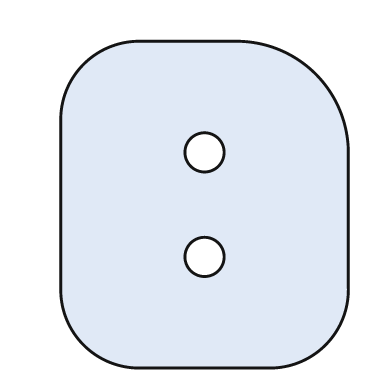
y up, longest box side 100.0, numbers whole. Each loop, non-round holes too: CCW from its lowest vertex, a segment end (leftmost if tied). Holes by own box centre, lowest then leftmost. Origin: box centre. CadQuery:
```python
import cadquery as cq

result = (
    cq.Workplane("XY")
    .moveTo(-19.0, -50.0)
    .lineTo(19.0, -50.0)
    .threePointArc((37.0, -43.0), (44.0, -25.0))
    .lineTo(44.0, 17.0)
    .threePointArc((34.0, 40.0), (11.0, 50.0))
    .lineTo(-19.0, 50.0)
    .threePointArc((-37.0, 43.0), (-44.0, 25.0))
    .lineTo(-44.0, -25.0)
    .threePointArc((-37.0, -43.0), (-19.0, -50.0))
    .close()
    .moveTo(0.0, -16.0)
    .circle(6.0)
    .moveTo(0.0, 16.0)
    .circle(6.0)
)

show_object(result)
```